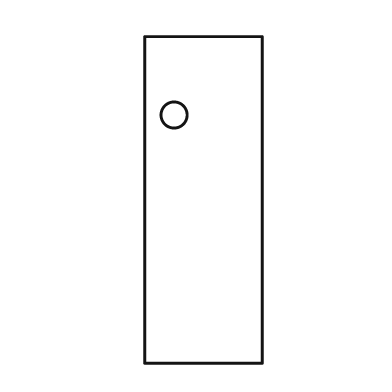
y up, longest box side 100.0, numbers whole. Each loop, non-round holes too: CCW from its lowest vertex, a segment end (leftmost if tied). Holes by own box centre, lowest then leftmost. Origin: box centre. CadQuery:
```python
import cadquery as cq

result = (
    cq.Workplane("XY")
    .moveTo(-18.0, -50.0)
    .lineTo(18.0, -50.0)
    .lineTo(18.0, 50.0)
    .lineTo(-18.0, 50.0)
    .close()
    .moveTo(-9.0, 26.0)
    .circle(4.0)
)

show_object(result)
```